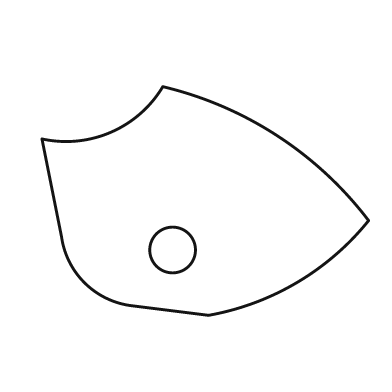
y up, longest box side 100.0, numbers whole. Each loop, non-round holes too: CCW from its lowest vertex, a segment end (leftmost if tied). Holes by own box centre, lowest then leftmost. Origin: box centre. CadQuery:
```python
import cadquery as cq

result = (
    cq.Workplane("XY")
    .moveTo(1.0, -35.0)
    .threePointArc((28.0, -25.0), (50.0, -6.0))
    .threePointArc((22.0, 20.0), (-13.0, 35.0))
    .threePointArc((-29.0, 21.0), (-50.0, 19.0))
    .lineTo(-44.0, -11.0)
    .threePointArc((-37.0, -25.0), (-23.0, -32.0))
    .close()
    .moveTo(-10.0, -15.0)
    .circle(7.0)
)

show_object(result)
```